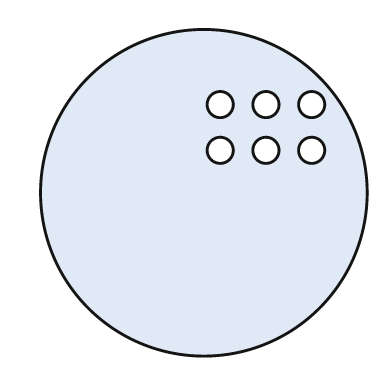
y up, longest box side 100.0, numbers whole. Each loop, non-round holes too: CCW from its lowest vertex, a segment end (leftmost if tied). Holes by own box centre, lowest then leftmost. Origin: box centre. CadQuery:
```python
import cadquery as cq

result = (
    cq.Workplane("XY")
    .moveTo(0.0, 0.0)
    .circle(50.0)
    .moveTo(5.0, 13.0)
    .circle(4.0)
    .moveTo(19.0, 13.0)
    .circle(4.0)
    .moveTo(33.0, 13.0)
    .circle(4.0)
    .moveTo(5.0, 27.0)
    .circle(4.0)
    .moveTo(19.0, 27.0)
    .circle(4.0)
    .moveTo(33.0, 27.0)
    .circle(4.0)
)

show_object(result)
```